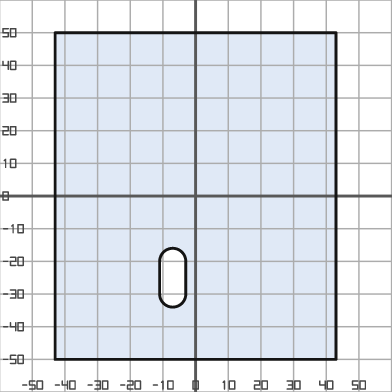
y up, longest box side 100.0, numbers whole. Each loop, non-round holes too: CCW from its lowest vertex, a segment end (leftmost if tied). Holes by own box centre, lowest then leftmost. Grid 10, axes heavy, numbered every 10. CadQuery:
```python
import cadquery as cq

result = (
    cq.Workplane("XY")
    .moveTo(-43.0, -50.0)
    .lineTo(43.0, -50.0)
    .lineTo(43.0, 50.0)
    .lineTo(-43.0, 50.0)
    .close()
    .moveTo(-11.0, -30.0)
    .threePointArc((-7.0, -34.0), (-3.0, -30.0))
    .lineTo(-3.0, -20.0)
    .threePointArc((-7.0, -16.0), (-11.0, -20.0))
    .close()
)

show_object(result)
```